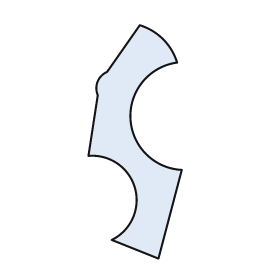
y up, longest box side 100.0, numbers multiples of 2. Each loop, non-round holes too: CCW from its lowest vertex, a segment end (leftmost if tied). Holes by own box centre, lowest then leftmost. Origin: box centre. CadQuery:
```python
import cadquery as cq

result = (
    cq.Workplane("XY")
    .moveTo(10.0, -50.0)
    .lineTo(20.0, -12.0)
    .threePointArc((-2.0, 10.0), (18.0, 34.0))
    .threePointArc((12.0, 44.0), (2.0, 50.0))
    .lineTo(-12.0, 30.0)
    .threePointArc((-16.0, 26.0), (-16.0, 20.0))
    .lineTo(-20.0, -6.0)
    .threePointArc((0.0, -20.0), (-10.0, -42.0))
    .close()
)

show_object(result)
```